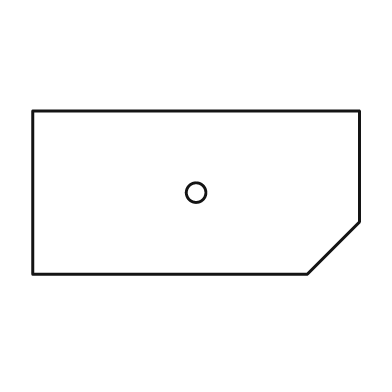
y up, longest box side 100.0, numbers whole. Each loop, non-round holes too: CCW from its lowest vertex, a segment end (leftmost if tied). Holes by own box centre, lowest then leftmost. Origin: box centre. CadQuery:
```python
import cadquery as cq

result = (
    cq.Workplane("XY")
    .moveTo(-50.0, -25.0)
    .lineTo(34.0, -25.0)
    .lineTo(50.0, -9.0)
    .lineTo(50.0, 25.0)
    .lineTo(-50.0, 25.0)
    .close()
    .moveTo(0.0, 0.0)
    .circle(3.0)
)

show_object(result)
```